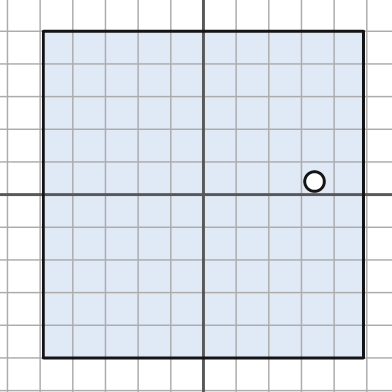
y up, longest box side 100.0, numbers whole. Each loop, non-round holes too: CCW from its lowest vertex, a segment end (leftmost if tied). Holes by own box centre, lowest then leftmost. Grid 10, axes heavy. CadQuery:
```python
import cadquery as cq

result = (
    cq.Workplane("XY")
    .moveTo(-49.0, -50.0)
    .lineTo(49.0, -50.0)
    .lineTo(49.0, 50.0)
    .lineTo(-49.0, 50.0)
    .close()
    .moveTo(34.0, 4.0)
    .circle(3.0)
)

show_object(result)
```